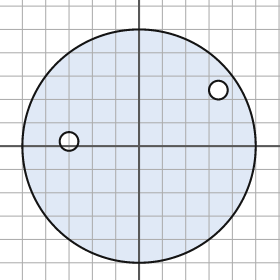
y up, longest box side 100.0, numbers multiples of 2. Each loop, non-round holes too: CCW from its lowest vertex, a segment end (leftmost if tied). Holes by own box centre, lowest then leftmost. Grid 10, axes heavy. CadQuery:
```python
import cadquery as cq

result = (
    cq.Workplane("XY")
    .moveTo(0.0, 0.0)
    .circle(50.0)
    .moveTo(-30.0, 2.0)
    .circle(4.0)
    .moveTo(34.0, 24.0)
    .circle(4.0)
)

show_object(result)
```